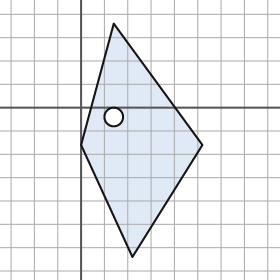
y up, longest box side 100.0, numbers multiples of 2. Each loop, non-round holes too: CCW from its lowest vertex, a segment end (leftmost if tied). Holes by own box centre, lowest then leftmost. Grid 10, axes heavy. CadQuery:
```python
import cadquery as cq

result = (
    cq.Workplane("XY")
    .moveTo(22.0, -64.0)
    .lineTo(52.0, -16.0)
    .lineTo(14.0, 36.0)
    .lineTo(0.0, -16.0)
    .close()
    .moveTo(14.0, -4.0)
    .circle(4.0)
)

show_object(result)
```